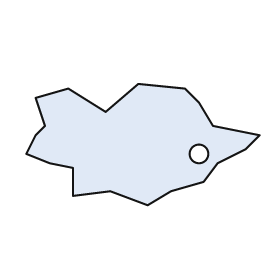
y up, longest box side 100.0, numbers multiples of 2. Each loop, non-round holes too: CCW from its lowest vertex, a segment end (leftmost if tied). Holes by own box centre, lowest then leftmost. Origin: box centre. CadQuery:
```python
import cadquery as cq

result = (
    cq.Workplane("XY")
    .moveTo(2.0, -26.0)
    .lineTo(12.0, -20.0)
    .lineTo(26.0, -16.0)
    .lineTo(32.0, -8.0)
    .lineTo(44.0, -2.0)
    .lineTo(50.0, 4.0)
    .lineTo(30.0, 8.0)
    .lineTo(24.0, 18.0)
    .lineTo(18.0, 24.0)
    .lineTo(-2.0, 26.0)
    .lineTo(-16.0, 14.0)
    .lineTo(-32.0, 24.0)
    .lineTo(-46.0, 20.0)
    .lineTo(-42.0, 8.0)
    .lineTo(-46.0, 4.0)
    .lineTo(-50.0, -4.0)
    .lineTo(-40.0, -8.0)
    .lineTo(-30.0, -10.0)
    .lineTo(-30.0, -22.0)
    .lineTo(-14.0, -20.0)
    .close()
    .moveTo(24.0, -4.0)
    .circle(4.0)
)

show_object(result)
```